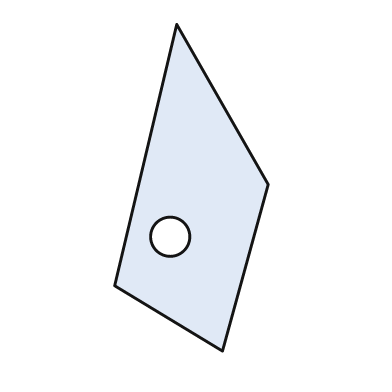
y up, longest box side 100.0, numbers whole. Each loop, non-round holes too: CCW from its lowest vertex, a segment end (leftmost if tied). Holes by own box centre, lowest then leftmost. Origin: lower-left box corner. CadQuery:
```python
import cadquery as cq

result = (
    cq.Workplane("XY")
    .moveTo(33.0, 0.0)
    .lineTo(47.0, 51.0)
    .lineTo(19.0, 100.0)
    .lineTo(0.0, 20.0)
    .close()
    .moveTo(17.0, 35.0)
    .circle(6.0)
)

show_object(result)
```